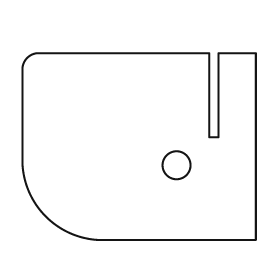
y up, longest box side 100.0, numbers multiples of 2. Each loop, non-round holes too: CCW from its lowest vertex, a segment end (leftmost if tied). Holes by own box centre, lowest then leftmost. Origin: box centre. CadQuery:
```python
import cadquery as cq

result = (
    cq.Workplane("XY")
    .moveTo(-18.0, -40.0)
    .lineTo(50.0, -40.0)
    .lineTo(50.0, 40.0)
    .lineTo(34.0, 40.0)
    .lineTo(34.0, 4.0)
    .lineTo(30.0, 4.0)
    .lineTo(30.0, 40.0)
    .lineTo(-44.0, 40.0)
    .threePointArc((-48.0, 38.0), (-50.0, 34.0))
    .lineTo(-50.0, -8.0)
    .threePointArc((-40.0, -30.0), (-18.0, -40.0))
    .close()
    .moveTo(16.0, -8.0)
    .circle(6.0)
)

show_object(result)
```